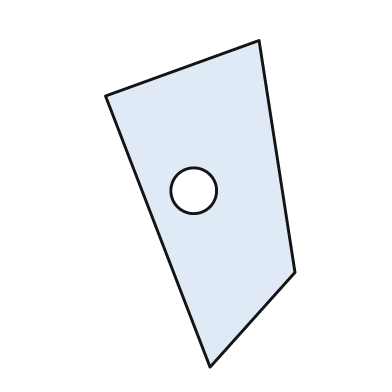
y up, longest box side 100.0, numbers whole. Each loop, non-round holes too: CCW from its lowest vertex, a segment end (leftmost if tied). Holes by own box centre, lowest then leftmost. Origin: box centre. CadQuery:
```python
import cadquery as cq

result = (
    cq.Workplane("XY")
    .moveTo(3.0, -50.0)
    .lineTo(29.0, -21.0)
    .lineTo(18.0, 50.0)
    .lineTo(-29.0, 33.0)
    .close()
    .moveTo(-2.0, 4.0)
    .circle(7.0)
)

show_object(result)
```